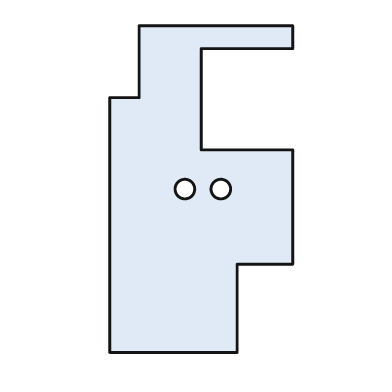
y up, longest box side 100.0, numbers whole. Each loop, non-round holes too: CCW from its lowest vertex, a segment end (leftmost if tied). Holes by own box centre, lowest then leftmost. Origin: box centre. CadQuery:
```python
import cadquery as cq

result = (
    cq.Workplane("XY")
    .moveTo(-28.0, -50.0)
    .lineTo(11.0, -50.0)
    .lineTo(11.0, -23.0)
    .lineTo(28.0, -23.0)
    .lineTo(28.0, 12.0)
    .lineTo(0.0, 12.0)
    .lineTo(0.0, 43.0)
    .lineTo(28.0, 43.0)
    .lineTo(28.0, 50.0)
    .lineTo(-19.0, 50.0)
    .lineTo(-19.0, 28.0)
    .lineTo(-28.0, 28.0)
    .close()
    .moveTo(-5.0, 0.0)
    .circle(3.0)
    .moveTo(6.0, 0.0)
    .circle(3.0)
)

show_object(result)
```